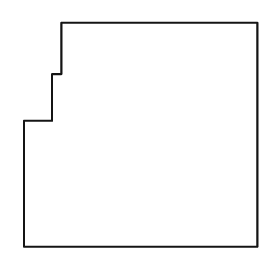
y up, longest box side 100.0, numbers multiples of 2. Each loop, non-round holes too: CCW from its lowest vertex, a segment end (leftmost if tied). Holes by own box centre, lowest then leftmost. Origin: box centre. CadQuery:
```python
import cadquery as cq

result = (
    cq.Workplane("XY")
    .moveTo(-50.0, -48.0)
    .lineTo(50.0, -48.0)
    .lineTo(50.0, 48.0)
    .lineTo(-34.0, 48.0)
    .lineTo(-34.0, 26.0)
    .lineTo(-38.0, 26.0)
    .lineTo(-38.0, 6.0)
    .lineTo(-50.0, 6.0)
    .close()
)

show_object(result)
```